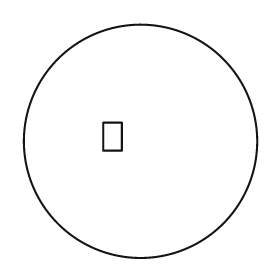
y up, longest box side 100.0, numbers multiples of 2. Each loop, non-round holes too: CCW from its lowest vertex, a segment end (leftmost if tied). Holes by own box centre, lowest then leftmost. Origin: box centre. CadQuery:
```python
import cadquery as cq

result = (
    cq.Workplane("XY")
    .moveTo(0.0, 0.0)
    .circle(50.0)
    .moveTo(-16.0, -4.0)
    .lineTo(-8.0, -4.0)
    .lineTo(-8.0, 8.0)
    .lineTo(-16.0, 8.0)
    .close()
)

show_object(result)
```